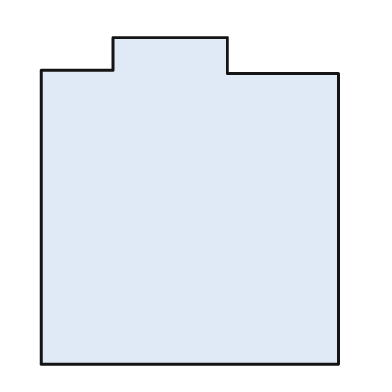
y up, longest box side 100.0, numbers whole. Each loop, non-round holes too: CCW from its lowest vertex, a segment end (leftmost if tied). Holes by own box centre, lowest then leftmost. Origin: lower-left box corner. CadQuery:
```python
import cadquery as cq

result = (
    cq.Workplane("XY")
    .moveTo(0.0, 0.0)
    .lineTo(91.0, 0.0)
    .lineTo(91.0, 89.0)
    .lineTo(57.0, 89.0)
    .lineTo(57.0, 100.0)
    .lineTo(22.0, 100.0)
    .lineTo(22.0, 90.0)
    .lineTo(0.0, 90.0)
    .close()
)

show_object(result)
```